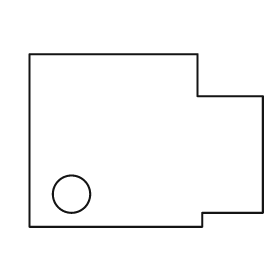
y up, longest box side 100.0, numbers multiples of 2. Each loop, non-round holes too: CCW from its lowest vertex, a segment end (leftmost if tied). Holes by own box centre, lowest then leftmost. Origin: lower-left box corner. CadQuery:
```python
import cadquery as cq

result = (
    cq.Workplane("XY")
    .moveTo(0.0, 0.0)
    .lineTo(74.0, 0.0)
    .lineTo(74.0, 6.0)
    .lineTo(100.0, 6.0)
    .lineTo(100.0, 56.0)
    .lineTo(72.0, 56.0)
    .lineTo(72.0, 74.0)
    .lineTo(0.0, 74.0)
    .close()
    .moveTo(18.0, 14.0)
    .circle(8.0)
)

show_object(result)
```